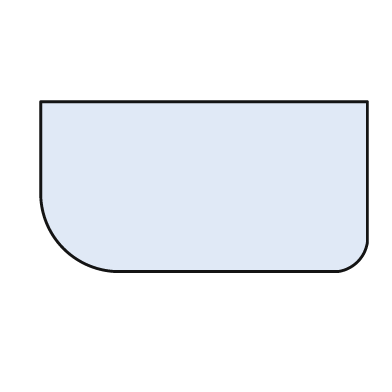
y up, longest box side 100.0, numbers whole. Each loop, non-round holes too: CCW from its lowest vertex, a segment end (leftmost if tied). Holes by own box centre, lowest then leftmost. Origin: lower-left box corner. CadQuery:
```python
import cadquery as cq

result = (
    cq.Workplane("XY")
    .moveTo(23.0, 0.0)
    .lineTo(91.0, 0.0)
    .threePointArc((97.0, 3.0), (100.0, 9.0))
    .lineTo(100.0, 52.0)
    .lineTo(0.0, 52.0)
    .lineTo(0.0, 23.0)
    .threePointArc((7.0, 7.0), (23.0, 0.0))
    .close()
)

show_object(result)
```